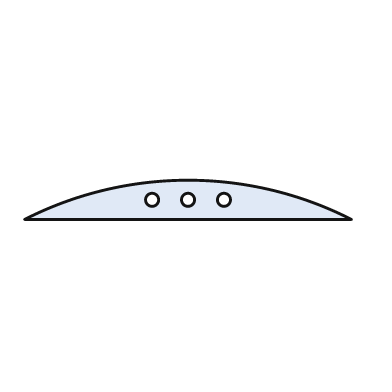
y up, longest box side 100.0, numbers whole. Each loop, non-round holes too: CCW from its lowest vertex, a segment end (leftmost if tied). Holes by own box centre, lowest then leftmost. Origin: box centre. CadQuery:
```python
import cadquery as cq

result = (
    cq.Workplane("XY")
    .moveTo(-50.0, -6.0)
    .lineTo(50.0, -6.0)
    .threePointArc((0.0, 6.0), (-50.0, -6.0))
    .close()
    .moveTo(-11.0, 0.0)
    .circle(2.0)
    .moveTo(0.0, 0.0)
    .circle(2.0)
    .moveTo(11.0, 0.0)
    .circle(2.0)
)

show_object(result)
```